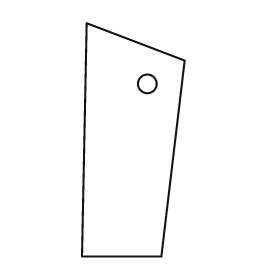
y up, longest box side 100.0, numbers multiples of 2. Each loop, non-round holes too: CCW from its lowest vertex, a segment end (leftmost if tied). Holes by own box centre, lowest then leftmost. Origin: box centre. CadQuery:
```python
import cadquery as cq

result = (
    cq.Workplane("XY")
    .moveTo(-22.0, -50.0)
    .lineTo(12.0, -50.0)
    .lineTo(22.0, 34.0)
    .lineTo(-20.0, 50.0)
    .close()
    .moveTo(6.0, 24.0)
    .circle(4.0)
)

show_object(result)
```